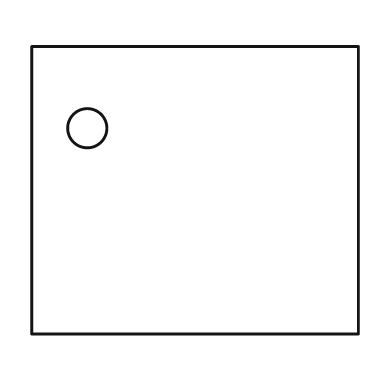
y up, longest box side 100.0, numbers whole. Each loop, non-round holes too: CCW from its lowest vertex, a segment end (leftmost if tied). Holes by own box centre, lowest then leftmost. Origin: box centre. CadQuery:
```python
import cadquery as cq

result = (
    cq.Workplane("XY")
    .moveTo(-50.0, -44.0)
    .lineTo(50.0, -44.0)
    .lineTo(50.0, 44.0)
    .lineTo(-50.0, 44.0)
    .close()
    .moveTo(-33.0, 19.0)
    .circle(6.0)
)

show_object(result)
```